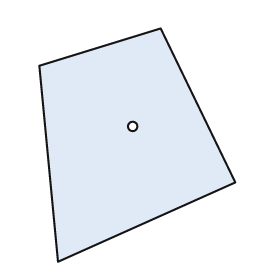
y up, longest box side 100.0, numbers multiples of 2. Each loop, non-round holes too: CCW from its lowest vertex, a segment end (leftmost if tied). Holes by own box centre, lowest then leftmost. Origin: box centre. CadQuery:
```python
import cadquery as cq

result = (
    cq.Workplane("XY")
    .moveTo(-34.0, -50.0)
    .lineTo(42.0, -16.0)
    .lineTo(10.0, 50.0)
    .lineTo(-42.0, 34.0)
    .close()
    .moveTo(-2.0, 8.0)
    .circle(2.0)
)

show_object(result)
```